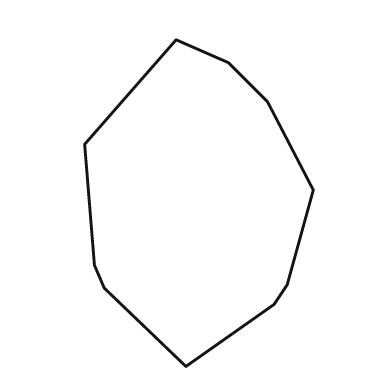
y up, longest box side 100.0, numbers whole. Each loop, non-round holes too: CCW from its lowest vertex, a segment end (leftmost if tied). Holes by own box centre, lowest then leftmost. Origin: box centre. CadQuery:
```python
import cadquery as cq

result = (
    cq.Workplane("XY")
    .moveTo(-4.0, -50.0)
    .lineTo(23.0, -31.0)
    .lineTo(27.0, -25.0)
    .lineTo(35.0, 4.0)
    .lineTo(21.0, 31.0)
    .lineTo(9.0, 43.0)
    .lineTo(-7.0, 50.0)
    .lineTo(-35.0, 18.0)
    .lineTo(-32.0, -19.0)
    .lineTo(-29.0, -26.0)
    .close()
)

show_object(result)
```